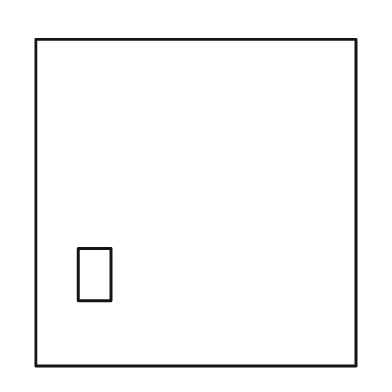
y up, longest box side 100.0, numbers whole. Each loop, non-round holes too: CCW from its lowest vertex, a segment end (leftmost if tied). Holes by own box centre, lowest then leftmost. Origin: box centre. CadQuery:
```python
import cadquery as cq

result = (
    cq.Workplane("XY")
    .moveTo(-49.0, -50.0)
    .lineTo(49.0, -50.0)
    .lineTo(49.0, 50.0)
    .lineTo(-49.0, 50.0)
    .close()
    .moveTo(-36.0, -30.0)
    .lineTo(-26.0, -30.0)
    .lineTo(-26.0, -14.0)
    .lineTo(-36.0, -14.0)
    .close()
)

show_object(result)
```